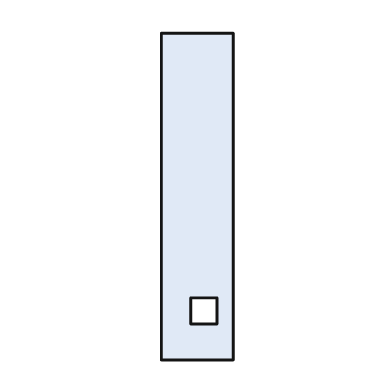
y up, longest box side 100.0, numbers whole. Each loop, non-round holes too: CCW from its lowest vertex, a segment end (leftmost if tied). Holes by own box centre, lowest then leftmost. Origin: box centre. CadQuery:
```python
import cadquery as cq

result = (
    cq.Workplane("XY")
    .moveTo(-11.0, -50.0)
    .lineTo(11.0, -50.0)
    .lineTo(11.0, 50.0)
    .lineTo(-11.0, 50.0)
    .close()
    .moveTo(-2.0, -39.0)
    .lineTo(6.0, -39.0)
    .lineTo(6.0, -31.0)
    .lineTo(-2.0, -31.0)
    .close()
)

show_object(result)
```